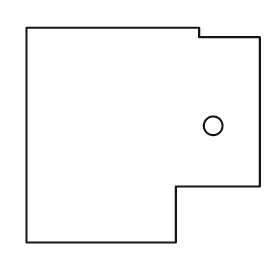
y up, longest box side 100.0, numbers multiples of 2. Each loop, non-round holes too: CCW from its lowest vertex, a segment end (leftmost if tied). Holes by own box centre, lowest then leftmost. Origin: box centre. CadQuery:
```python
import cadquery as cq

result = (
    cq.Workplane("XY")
    .moveTo(-50.0, -46.0)
    .lineTo(14.0, -46.0)
    .lineTo(14.0, -22.0)
    .lineTo(50.0, -22.0)
    .lineTo(50.0, 42.0)
    .lineTo(24.0, 42.0)
    .lineTo(24.0, 46.0)
    .lineTo(-50.0, 46.0)
    .close()
    .moveTo(30.0, 4.0)
    .circle(4.0)
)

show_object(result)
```